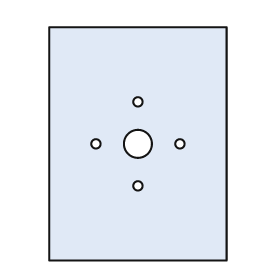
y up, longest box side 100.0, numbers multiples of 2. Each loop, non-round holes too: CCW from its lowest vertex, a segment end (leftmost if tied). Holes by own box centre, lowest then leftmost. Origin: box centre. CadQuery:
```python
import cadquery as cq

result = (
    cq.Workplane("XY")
    .moveTo(-38.0, -50.0)
    .lineTo(38.0, -50.0)
    .lineTo(38.0, 50.0)
    .lineTo(-38.0, 50.0)
    .close()
    .moveTo(0.0, -18.0)
    .circle(2.0)
    .moveTo(-18.0, 0.0)
    .circle(2.0)
    .moveTo(0.0, 0.0)
    .circle(6.0)
    .moveTo(18.0, 0.0)
    .circle(2.0)
    .moveTo(0.0, 18.0)
    .circle(2.0)
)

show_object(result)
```